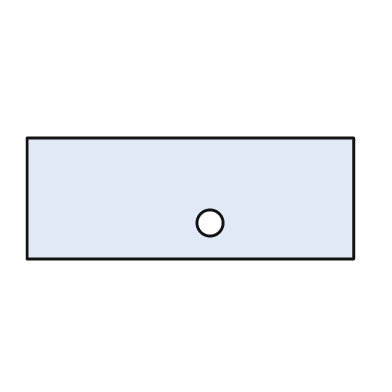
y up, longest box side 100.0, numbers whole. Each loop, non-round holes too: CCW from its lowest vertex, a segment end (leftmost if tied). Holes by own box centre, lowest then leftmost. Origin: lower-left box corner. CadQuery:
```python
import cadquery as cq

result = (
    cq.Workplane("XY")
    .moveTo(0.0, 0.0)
    .lineTo(100.0, 0.0)
    .lineTo(100.0, 37.0)
    .lineTo(0.0, 37.0)
    .close()
    .moveTo(56.0, 11.0)
    .circle(4.0)
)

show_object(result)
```